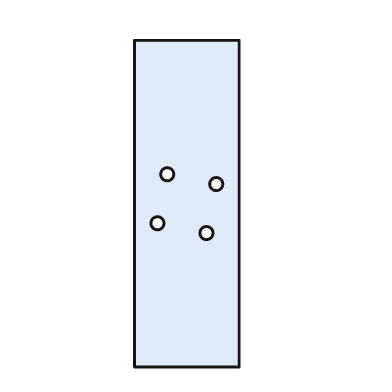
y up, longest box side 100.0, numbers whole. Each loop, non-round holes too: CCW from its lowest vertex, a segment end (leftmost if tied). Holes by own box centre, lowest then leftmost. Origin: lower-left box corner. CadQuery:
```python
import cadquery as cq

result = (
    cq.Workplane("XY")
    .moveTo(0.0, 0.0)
    .lineTo(32.0, 0.0)
    .lineTo(32.0, 100.0)
    .lineTo(0.0, 100.0)
    .close()
    .moveTo(22.0, 41.0)
    .circle(2.0)
    .moveTo(7.0, 44.0)
    .circle(2.0)
    .moveTo(25.0, 56.0)
    .circle(2.0)
    .moveTo(10.0, 59.0)
    .circle(2.0)
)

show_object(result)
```